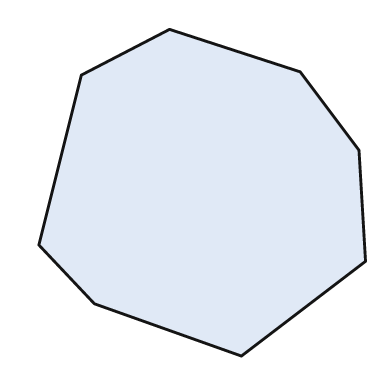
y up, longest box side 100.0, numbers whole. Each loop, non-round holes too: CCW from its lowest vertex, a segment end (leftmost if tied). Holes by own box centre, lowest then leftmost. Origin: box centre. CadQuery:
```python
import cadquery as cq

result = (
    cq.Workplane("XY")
    .moveTo(12.0, -50.0)
    .lineTo(50.0, -21.0)
    .lineTo(48.0, 13.0)
    .lineTo(30.0, 37.0)
    .lineTo(-10.0, 50.0)
    .lineTo(-37.0, 36.0)
    .lineTo(-50.0, -16.0)
    .lineTo(-33.0, -34.0)
    .close()
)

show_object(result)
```